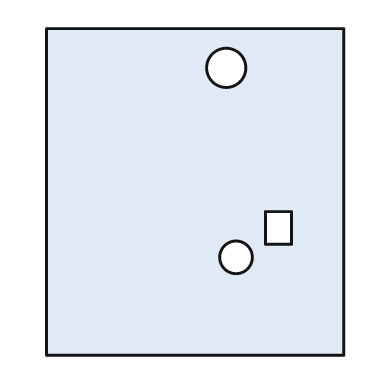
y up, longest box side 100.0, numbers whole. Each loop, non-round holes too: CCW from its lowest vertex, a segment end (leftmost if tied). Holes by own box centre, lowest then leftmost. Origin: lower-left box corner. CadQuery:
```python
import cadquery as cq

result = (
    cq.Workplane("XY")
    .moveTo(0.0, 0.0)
    .lineTo(91.0, 0.0)
    .lineTo(91.0, 100.0)
    .lineTo(0.0, 100.0)
    .close()
    .moveTo(58.0, 30.0)
    .circle(5.0)
    .moveTo(67.0, 34.0)
    .lineTo(75.0, 34.0)
    .lineTo(75.0, 44.0)
    .lineTo(67.0, 44.0)
    .close()
    .moveTo(55.0, 88.0)
    .circle(6.0)
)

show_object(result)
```